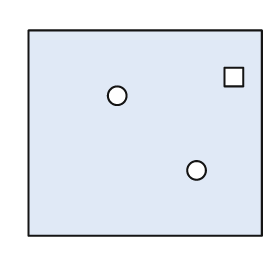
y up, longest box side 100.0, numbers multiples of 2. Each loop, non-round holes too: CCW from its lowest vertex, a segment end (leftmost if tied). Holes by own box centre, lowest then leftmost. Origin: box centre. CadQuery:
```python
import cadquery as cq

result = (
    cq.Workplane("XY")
    .moveTo(-50.0, -44.0)
    .lineTo(50.0, -44.0)
    .lineTo(50.0, 44.0)
    .lineTo(-50.0, 44.0)
    .close()
    .moveTo(22.0, -16.0)
    .circle(4.0)
    .moveTo(-12.0, 16.0)
    .circle(4.0)
    .moveTo(34.0, 20.0)
    .lineTo(42.0, 20.0)
    .lineTo(42.0, 28.0)
    .lineTo(34.0, 28.0)
    .close()
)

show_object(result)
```